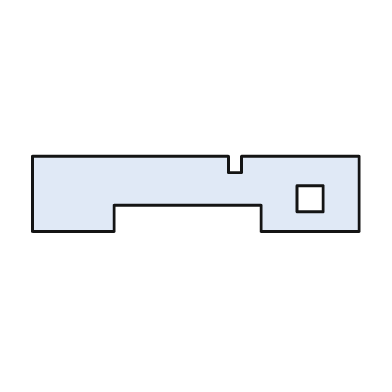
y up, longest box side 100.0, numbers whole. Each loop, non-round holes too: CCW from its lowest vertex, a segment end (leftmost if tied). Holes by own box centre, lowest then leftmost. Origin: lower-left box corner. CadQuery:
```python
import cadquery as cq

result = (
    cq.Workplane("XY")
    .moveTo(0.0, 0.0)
    .lineTo(25.0, 0.0)
    .lineTo(25.0, 8.0)
    .lineTo(70.0, 8.0)
    .lineTo(70.0, 0.0)
    .lineTo(100.0, 0.0)
    .lineTo(100.0, 23.0)
    .lineTo(64.0, 23.0)
    .lineTo(64.0, 18.0)
    .lineTo(60.0, 18.0)
    .lineTo(60.0, 23.0)
    .lineTo(0.0, 23.0)
    .close()
    .moveTo(81.0, 6.0)
    .lineTo(89.0, 6.0)
    .lineTo(89.0, 14.0)
    .lineTo(81.0, 14.0)
    .close()
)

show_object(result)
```